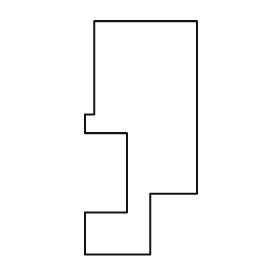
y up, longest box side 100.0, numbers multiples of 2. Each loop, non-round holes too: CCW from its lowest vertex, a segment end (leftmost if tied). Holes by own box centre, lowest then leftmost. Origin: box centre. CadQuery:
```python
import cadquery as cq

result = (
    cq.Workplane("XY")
    .moveTo(-24.0, -50.0)
    .lineTo(4.0, -50.0)
    .lineTo(4.0, -24.0)
    .lineTo(24.0, -24.0)
    .lineTo(24.0, 50.0)
    .lineTo(-20.0, 50.0)
    .lineTo(-20.0, 10.0)
    .lineTo(-24.0, 10.0)
    .lineTo(-24.0, 2.0)
    .lineTo(-6.0, 2.0)
    .lineTo(-6.0, -32.0)
    .lineTo(-24.0, -32.0)
    .close()
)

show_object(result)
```